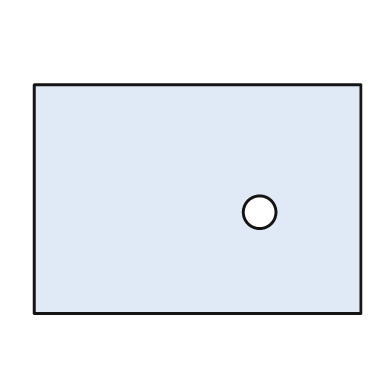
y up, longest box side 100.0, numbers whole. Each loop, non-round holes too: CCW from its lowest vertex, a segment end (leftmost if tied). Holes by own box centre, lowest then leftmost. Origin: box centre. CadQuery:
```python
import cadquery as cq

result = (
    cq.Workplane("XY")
    .moveTo(-50.0, -35.0)
    .lineTo(50.0, -35.0)
    .lineTo(50.0, 35.0)
    .lineTo(-50.0, 35.0)
    .close()
    .moveTo(19.0, -4.0)
    .circle(5.0)
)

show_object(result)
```